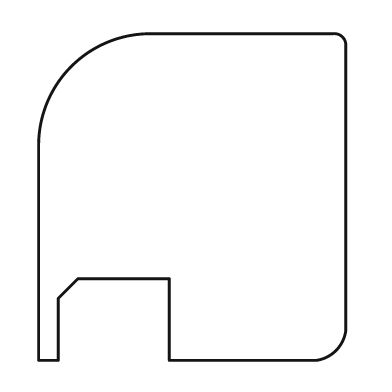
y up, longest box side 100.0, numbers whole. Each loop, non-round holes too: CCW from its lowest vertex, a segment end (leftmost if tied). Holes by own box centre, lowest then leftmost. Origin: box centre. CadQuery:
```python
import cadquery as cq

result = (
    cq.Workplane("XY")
    .moveTo(-47.0, -50.0)
    .lineTo(-41.0, -50.0)
    .lineTo(-41.0, -31.0)
    .lineTo(-35.0, -25.0)
    .lineTo(-7.0, -25.0)
    .lineTo(-7.0, -50.0)
    .lineTo(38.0, -50.0)
    .threePointArc((44.0, -47.0), (47.0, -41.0))
    .lineTo(47.0, 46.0)
    .threePointArc((46.0, 49.0), (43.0, 50.0))
    .lineTo(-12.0, 50.0)
    .threePointArc((-37.0, 40.0), (-47.0, 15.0))
    .close()
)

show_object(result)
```